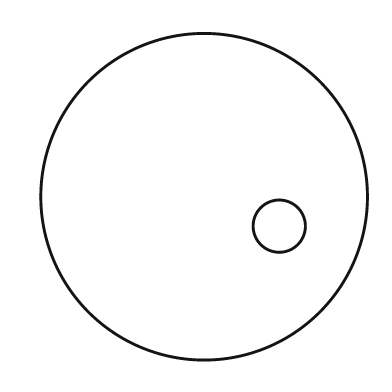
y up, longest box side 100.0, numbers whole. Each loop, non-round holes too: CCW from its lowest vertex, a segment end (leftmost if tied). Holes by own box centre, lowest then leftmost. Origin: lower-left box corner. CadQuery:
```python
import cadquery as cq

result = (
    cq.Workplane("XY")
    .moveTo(50.0, 50.0)
    .circle(50.0)
    .moveTo(73.0, 41.0)
    .circle(8.0)
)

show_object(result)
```